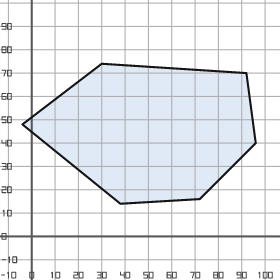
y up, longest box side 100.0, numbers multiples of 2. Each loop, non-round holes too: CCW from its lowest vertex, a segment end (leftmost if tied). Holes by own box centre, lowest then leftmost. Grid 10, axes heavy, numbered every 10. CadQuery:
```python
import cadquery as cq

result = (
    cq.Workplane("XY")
    .moveTo(38.0, 14.0)
    .lineTo(72.0, 16.0)
    .lineTo(96.0, 40.0)
    .lineTo(92.0, 70.0)
    .lineTo(30.0, 74.0)
    .lineTo(-4.0, 48.0)
    .close()
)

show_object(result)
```